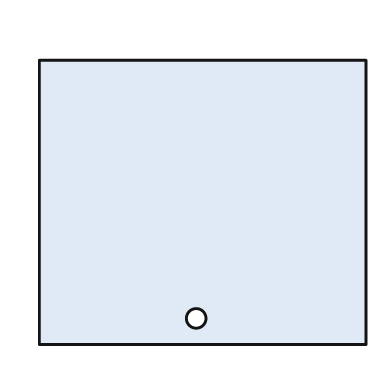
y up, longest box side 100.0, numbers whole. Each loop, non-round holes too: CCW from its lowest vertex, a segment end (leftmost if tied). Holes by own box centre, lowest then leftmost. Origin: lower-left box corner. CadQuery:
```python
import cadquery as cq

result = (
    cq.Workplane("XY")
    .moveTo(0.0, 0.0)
    .lineTo(100.0, 0.0)
    .lineTo(100.0, 87.0)
    .lineTo(0.0, 87.0)
    .close()
    .moveTo(48.0, 8.0)
    .circle(3.0)
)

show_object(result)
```